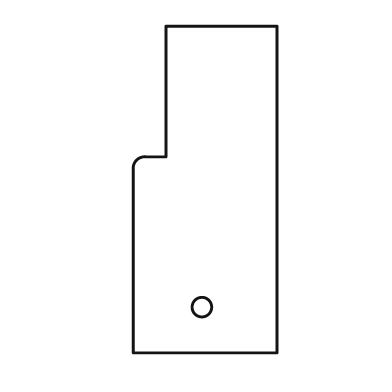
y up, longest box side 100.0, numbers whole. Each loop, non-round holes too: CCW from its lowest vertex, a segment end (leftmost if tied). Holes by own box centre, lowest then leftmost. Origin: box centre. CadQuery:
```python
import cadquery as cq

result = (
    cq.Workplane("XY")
    .moveTo(-22.0, -50.0)
    .lineTo(22.0, -50.0)
    .lineTo(22.0, 50.0)
    .lineTo(-12.0, 50.0)
    .lineTo(-12.0, 10.0)
    .lineTo(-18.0, 10.0)
    .threePointArc((-21.0, 9.0), (-22.0, 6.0))
    .close()
    .moveTo(-1.0, -36.0)
    .circle(3.0)
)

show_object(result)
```